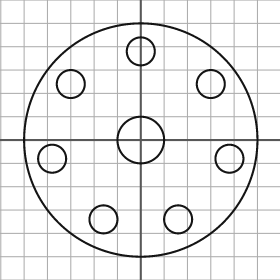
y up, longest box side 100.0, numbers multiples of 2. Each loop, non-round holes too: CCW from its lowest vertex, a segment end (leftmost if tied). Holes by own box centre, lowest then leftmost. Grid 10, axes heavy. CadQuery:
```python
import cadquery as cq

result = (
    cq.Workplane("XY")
    .moveTo(0.0, 0.0)
    .circle(50.0)
    .moveTo(-16.0, -34.0)
    .circle(6.0)
    .moveTo(16.0, -34.0)
    .circle(6.0)
    .moveTo(-38.0, -8.0)
    .circle(6.0)
    .moveTo(38.0, -8.0)
    .circle(6.0)
    .moveTo(0.0, 0.0)
    .circle(10.0)
    .moveTo(-30.0, 24.0)
    .circle(6.0)
    .moveTo(30.0, 24.0)
    .circle(6.0)
    .moveTo(0.0, 38.0)
    .circle(6.0)
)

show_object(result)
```